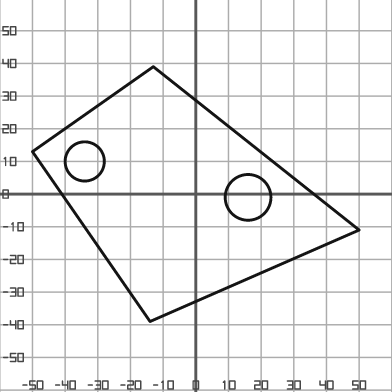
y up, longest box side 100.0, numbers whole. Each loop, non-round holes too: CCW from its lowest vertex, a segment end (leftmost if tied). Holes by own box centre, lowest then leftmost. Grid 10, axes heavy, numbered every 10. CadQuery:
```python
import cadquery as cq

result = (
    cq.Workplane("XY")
    .moveTo(-14.0, -39.0)
    .lineTo(50.0, -11.0)
    .lineTo(-13.0, 39.0)
    .lineTo(-50.0, 13.0)
    .close()
    .moveTo(16.0, -1.0)
    .circle(7.0)
    .moveTo(-34.0, 10.0)
    .circle(6.0)
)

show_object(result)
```